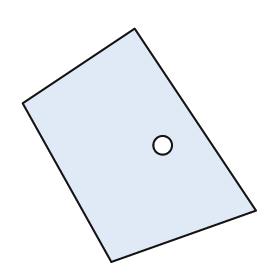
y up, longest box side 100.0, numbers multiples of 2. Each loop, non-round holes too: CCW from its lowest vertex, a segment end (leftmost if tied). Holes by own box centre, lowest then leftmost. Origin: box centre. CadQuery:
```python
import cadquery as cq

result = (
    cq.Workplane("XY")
    .moveTo(-12.0, -50.0)
    .lineTo(50.0, -28.0)
    .lineTo(-2.0, 50.0)
    .lineTo(-50.0, 18.0)
    .close()
    .moveTo(10.0, 0.0)
    .circle(4.0)
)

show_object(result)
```